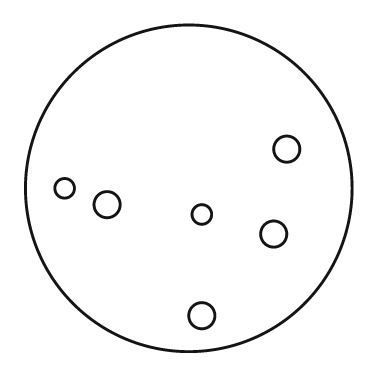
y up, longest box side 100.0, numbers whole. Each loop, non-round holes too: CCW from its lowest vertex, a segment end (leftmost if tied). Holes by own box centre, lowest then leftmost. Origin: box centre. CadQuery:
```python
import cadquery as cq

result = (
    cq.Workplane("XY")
    .moveTo(0.0, 0.0)
    .circle(50.0)
    .moveTo(4.0, -39.0)
    .circle(4.0)
    .moveTo(26.0, -14.0)
    .circle(4.0)
    .moveTo(4.0, -8.0)
    .circle(3.0)
    .moveTo(-25.0, -5.0)
    .circle(4.0)
    .moveTo(-38.0, 0.0)
    .circle(3.0)
    .moveTo(30.0, 12.0)
    .circle(4.0)
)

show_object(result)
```